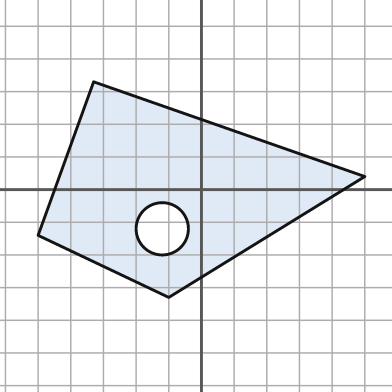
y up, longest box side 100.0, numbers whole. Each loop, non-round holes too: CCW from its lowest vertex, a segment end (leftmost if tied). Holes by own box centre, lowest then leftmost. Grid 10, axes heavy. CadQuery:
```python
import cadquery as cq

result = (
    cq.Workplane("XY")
    .moveTo(-10.0, -33.0)
    .lineTo(50.0, 4.0)
    .lineTo(-33.0, 33.0)
    .lineTo(-50.0, -14.0)
    .close()
    .moveTo(-12.0, -12.0)
    .circle(8.0)
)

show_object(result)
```